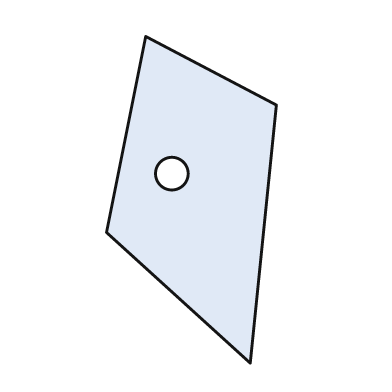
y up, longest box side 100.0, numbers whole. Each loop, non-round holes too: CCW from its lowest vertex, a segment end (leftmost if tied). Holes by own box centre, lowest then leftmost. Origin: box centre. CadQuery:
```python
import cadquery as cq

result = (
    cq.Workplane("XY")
    .moveTo(18.0, -50.0)
    .lineTo(26.0, 29.0)
    .lineTo(-14.0, 50.0)
    .lineTo(-26.0, -10.0)
    .close()
    .moveTo(-6.0, 8.0)
    .circle(5.0)
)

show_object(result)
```